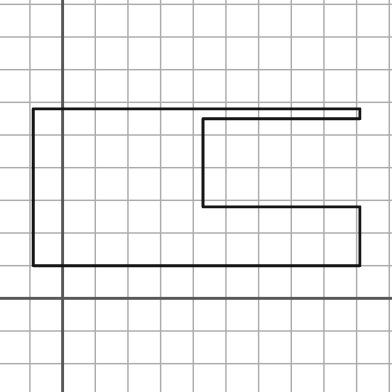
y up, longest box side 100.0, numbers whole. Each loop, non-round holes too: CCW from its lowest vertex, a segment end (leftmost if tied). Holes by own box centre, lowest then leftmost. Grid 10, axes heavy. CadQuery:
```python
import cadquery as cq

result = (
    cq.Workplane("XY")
    .moveTo(-9.0, 10.0)
    .lineTo(91.0, 10.0)
    .lineTo(91.0, 28.0)
    .lineTo(43.0, 28.0)
    .lineTo(43.0, 55.0)
    .lineTo(91.0, 55.0)
    .lineTo(91.0, 58.0)
    .lineTo(-9.0, 58.0)
    .close()
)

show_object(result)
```